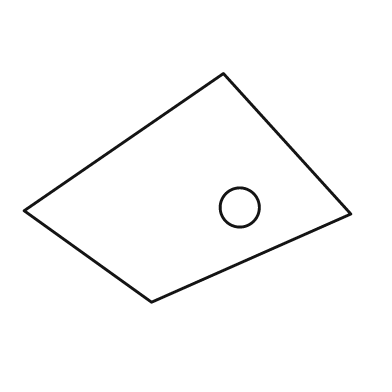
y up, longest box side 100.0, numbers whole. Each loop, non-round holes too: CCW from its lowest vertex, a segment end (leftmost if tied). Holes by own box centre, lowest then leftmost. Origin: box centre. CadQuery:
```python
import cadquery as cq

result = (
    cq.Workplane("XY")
    .moveTo(-11.0, -35.0)
    .lineTo(50.0, -8.0)
    .lineTo(11.0, 35.0)
    .lineTo(-50.0, -7.0)
    .close()
    .moveTo(16.0, -6.0)
    .circle(6.0)
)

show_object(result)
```